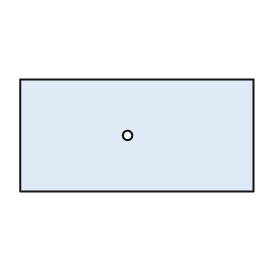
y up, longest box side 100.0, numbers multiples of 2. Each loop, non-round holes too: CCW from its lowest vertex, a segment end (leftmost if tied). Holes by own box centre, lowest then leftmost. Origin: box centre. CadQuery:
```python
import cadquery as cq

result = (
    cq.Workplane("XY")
    .moveTo(-50.0, -24.0)
    .lineTo(50.0, -24.0)
    .lineTo(50.0, 24.0)
    .lineTo(-50.0, 24.0)
    .close()
    .moveTo(-4.0, 0.0)
    .circle(2.0)
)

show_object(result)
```